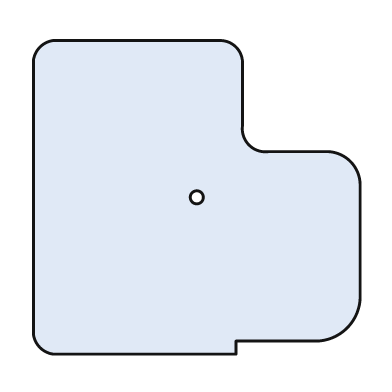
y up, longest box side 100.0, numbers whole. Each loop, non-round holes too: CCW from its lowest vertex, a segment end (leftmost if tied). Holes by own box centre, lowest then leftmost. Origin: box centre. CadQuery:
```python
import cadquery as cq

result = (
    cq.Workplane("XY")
    .moveTo(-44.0, -48.0)
    .lineTo(12.0, -48.0)
    .lineTo(12.0, -44.0)
    .lineTo(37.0, -44.0)
    .threePointArc((46.0, -40.0), (50.0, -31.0))
    .lineTo(50.0, 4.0)
    .threePointArc((47.0, 11.0), (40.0, 14.0))
    .lineTo(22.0, 14.0)
    .threePointArc((16.0, 16.0), (14.0, 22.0))
    .lineTo(14.0, 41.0)
    .threePointArc((12.0, 46.0), (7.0, 48.0))
    .lineTo(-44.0, 48.0)
    .threePointArc((-48.0, 46.0), (-50.0, 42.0))
    .lineTo(-50.0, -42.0)
    .threePointArc((-48.0, -46.0), (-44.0, -48.0))
    .close()
    .moveTo(0.0, 0.0)
    .circle(2.0)
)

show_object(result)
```